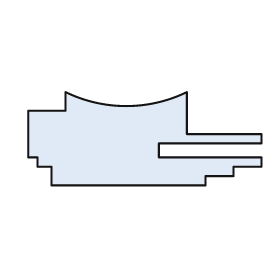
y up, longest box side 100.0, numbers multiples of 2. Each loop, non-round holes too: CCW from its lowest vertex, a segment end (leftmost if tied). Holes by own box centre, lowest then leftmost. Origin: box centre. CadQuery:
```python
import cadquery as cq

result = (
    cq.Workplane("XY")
    .moveTo(-40.0, -20.0)
    .lineTo(26.0, -20.0)
    .lineTo(26.0, -16.0)
    .lineTo(38.0, -16.0)
    .lineTo(38.0, -12.0)
    .lineTo(50.0, -12.0)
    .lineTo(50.0, -8.0)
    .lineTo(6.0, -8.0)
    .lineTo(6.0, -2.0)
    .lineTo(50.0, -2.0)
    .lineTo(50.0, 2.0)
    .lineTo(18.0, 2.0)
    .lineTo(18.0, 20.0)
    .threePointArc((-8.0, 14.0), (-34.0, 20.0))
    .lineTo(-34.0, 12.0)
    .lineTo(-50.0, 12.0)
    .lineTo(-50.0, -8.0)
    .lineTo(-46.0, -8.0)
    .lineTo(-46.0, -12.0)
    .lineTo(-40.0, -12.0)
    .close()
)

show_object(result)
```